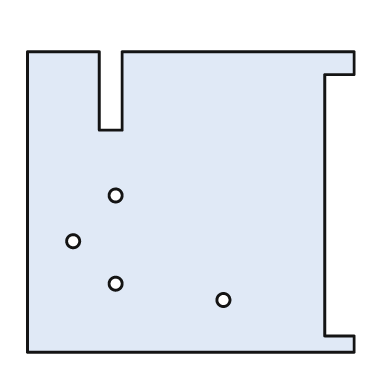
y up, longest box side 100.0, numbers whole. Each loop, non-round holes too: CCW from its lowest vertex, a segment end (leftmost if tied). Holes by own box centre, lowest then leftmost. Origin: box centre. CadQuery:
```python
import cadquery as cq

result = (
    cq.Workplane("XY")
    .moveTo(-50.0, -46.0)
    .lineTo(50.0, -46.0)
    .lineTo(50.0, -41.0)
    .lineTo(41.0, -41.0)
    .lineTo(41.0, 39.0)
    .lineTo(50.0, 39.0)
    .lineTo(50.0, 46.0)
    .lineTo(-21.0, 46.0)
    .lineTo(-21.0, 22.0)
    .lineTo(-28.0, 22.0)
    .lineTo(-28.0, 46.0)
    .lineTo(-50.0, 46.0)
    .close()
    .moveTo(10.0, -30.0)
    .circle(2.0)
    .moveTo(-23.0, -25.0)
    .circle(2.0)
    .moveTo(-36.0, -12.0)
    .circle(2.0)
    .moveTo(-23.0, 2.0)
    .circle(2.0)
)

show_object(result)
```